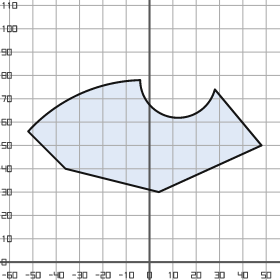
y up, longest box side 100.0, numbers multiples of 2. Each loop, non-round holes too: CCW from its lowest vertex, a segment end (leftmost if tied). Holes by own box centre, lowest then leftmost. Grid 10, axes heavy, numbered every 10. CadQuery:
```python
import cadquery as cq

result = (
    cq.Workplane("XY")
    .moveTo(4.0, 30.0)
    .lineTo(48.0, 50.0)
    .lineTo(28.0, 74.0)
    .threePointArc((10.0, 62.0), (-4.0, 78.0))
    .threePointArc((-30.0, 72.0), (-52.0, 56.0))
    .lineTo(-36.0, 40.0)
    .close()
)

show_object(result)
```